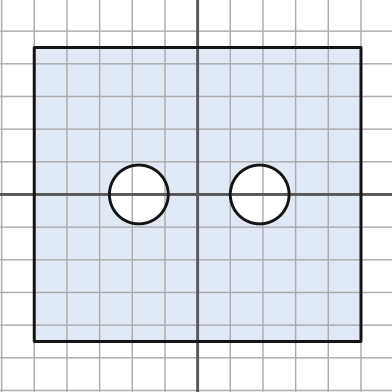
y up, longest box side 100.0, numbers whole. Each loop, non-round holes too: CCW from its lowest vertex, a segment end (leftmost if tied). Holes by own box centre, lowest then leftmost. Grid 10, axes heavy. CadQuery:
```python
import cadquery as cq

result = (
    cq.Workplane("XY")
    .moveTo(-50.0, -45.0)
    .lineTo(50.0, -45.0)
    .lineTo(50.0, 45.0)
    .lineTo(-50.0, 45.0)
    .close()
    .moveTo(-18.0, 0.0)
    .circle(9.0)
    .moveTo(19.0, 0.0)
    .circle(9.0)
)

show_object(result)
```